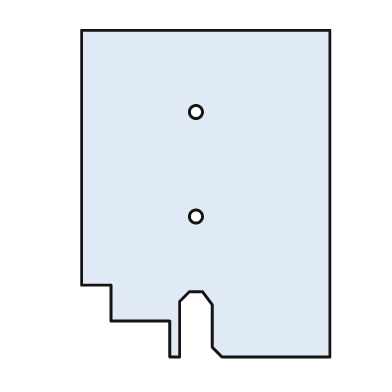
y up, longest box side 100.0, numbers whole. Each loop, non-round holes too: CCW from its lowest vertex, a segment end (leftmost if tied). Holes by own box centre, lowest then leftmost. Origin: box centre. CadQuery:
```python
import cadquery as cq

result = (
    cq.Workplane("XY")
    .moveTo(-11.0, -50.0)
    .lineTo(-8.0, -50.0)
    .lineTo(-8.0, -33.0)
    .lineTo(-5.0, -30.0)
    .lineTo(-1.0, -30.0)
    .lineTo(2.0, -34.0)
    .lineTo(2.0, -47.0)
    .lineTo(5.0, -50.0)
    .lineTo(38.0, -50.0)
    .lineTo(38.0, 50.0)
    .lineTo(-38.0, 50.0)
    .lineTo(-38.0, -28.0)
    .lineTo(-29.0, -28.0)
    .lineTo(-29.0, -39.0)
    .lineTo(-11.0, -39.0)
    .close()
    .moveTo(-3.0, -7.0)
    .circle(2.0)
    .moveTo(-3.0, 25.0)
    .circle(2.0)
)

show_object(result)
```